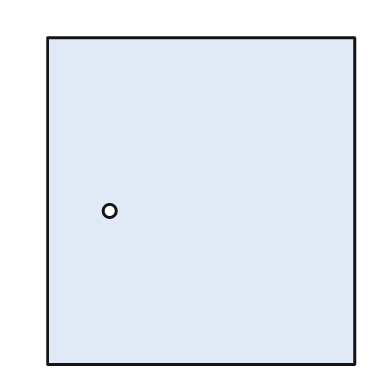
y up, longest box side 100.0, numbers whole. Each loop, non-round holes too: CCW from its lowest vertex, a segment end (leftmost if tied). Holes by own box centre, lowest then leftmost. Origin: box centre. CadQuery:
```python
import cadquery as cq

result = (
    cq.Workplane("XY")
    .moveTo(-47.0, -50.0)
    .lineTo(47.0, -50.0)
    .lineTo(47.0, 50.0)
    .lineTo(-47.0, 50.0)
    .close()
    .moveTo(-28.0, -3.0)
    .circle(2.0)
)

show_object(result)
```